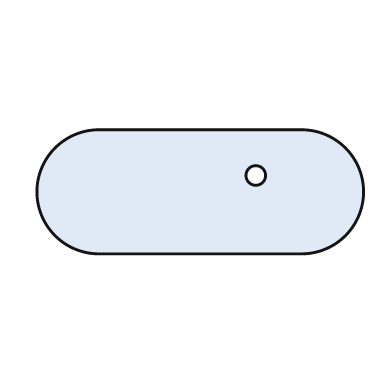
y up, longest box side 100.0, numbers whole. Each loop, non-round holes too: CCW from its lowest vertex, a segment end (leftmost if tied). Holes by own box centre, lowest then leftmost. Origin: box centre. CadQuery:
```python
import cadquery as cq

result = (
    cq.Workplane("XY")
    .moveTo(-31.0, -19.0)
    .lineTo(31.0, -19.0)
    .threePointArc((50.0, 0.0), (31.0, 19.0))
    .lineTo(-31.0, 19.0)
    .threePointArc((-50.0, 0.0), (-31.0, -19.0))
    .close()
    .moveTo(17.0, 5.0)
    .circle(3.0)
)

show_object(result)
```